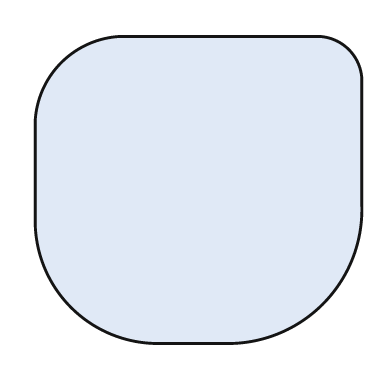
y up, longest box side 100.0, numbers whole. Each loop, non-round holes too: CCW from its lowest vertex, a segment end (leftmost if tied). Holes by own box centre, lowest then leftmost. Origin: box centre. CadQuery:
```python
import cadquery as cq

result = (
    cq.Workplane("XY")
    .moveTo(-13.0, -47.0)
    .lineTo(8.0, -47.0)
    .threePointArc((38.0, -35.0), (50.0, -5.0))
    .lineTo(50.0, 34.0)
    .threePointArc((46.0, 43.0), (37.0, 47.0))
    .lineTo(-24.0, 47.0)
    .threePointArc((-42.0, 39.0), (-50.0, 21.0))
    .lineTo(-50.0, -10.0)
    .threePointArc((-39.0, -36.0), (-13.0, -47.0))
    .close()
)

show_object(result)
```